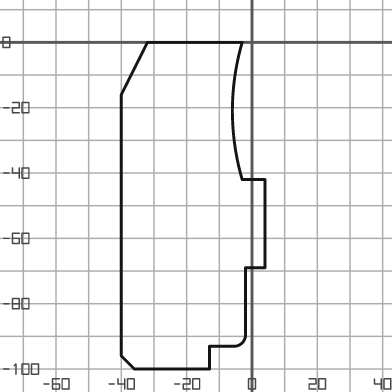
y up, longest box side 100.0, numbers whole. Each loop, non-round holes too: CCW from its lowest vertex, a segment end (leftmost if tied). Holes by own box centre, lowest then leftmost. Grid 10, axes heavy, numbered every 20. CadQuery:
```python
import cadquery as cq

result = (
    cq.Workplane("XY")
    .moveTo(-36.0, -100.0)
    .lineTo(-13.0, -100.0)
    .lineTo(-13.0, -93.0)
    .lineTo(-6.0, -93.0)
    .threePointArc((-3.0, -92.0), (-2.0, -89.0))
    .lineTo(-2.0, -69.0)
    .lineTo(4.0, -69.0)
    .lineTo(4.0, -42.0)
    .lineTo(-3.0, -42.0)
    .threePointArc((-6.0, -21.0), (-3.0, 0.0))
    .lineTo(-32.0, 0.0)
    .lineTo(-40.0, -16.0)
    .lineTo(-40.0, -96.0)
    .close()
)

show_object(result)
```